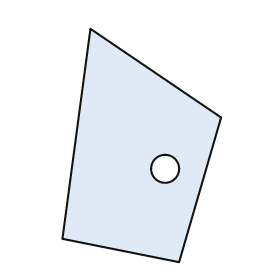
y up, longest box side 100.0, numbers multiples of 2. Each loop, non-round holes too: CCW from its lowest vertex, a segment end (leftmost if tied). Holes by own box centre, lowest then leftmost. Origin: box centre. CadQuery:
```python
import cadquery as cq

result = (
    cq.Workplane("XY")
    .moveTo(16.0, -50.0)
    .lineTo(34.0, 12.0)
    .lineTo(-22.0, 50.0)
    .lineTo(-34.0, -40.0)
    .close()
    .moveTo(10.0, -10.0)
    .circle(6.0)
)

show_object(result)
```